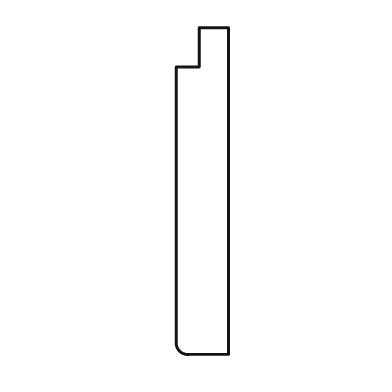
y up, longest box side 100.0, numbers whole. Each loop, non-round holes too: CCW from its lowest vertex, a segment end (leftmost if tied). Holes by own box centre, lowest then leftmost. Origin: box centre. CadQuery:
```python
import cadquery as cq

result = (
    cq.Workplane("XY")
    .moveTo(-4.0, -50.0)
    .lineTo(8.0, -50.0)
    .lineTo(8.0, 50.0)
    .lineTo(-1.0, 50.0)
    .lineTo(-1.0, 38.0)
    .lineTo(-8.0, 38.0)
    .lineTo(-8.0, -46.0)
    .threePointArc((-7.0, -49.0), (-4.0, -50.0))
    .close()
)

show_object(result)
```